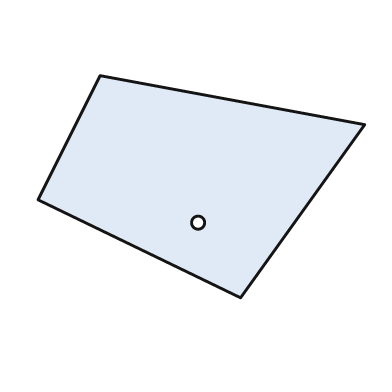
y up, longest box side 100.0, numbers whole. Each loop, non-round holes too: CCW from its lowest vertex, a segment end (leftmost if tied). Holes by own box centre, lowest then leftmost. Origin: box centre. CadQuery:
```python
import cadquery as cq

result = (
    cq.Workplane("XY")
    .moveTo(12.0, -34.0)
    .lineTo(50.0, 19.0)
    .lineTo(-31.0, 34.0)
    .lineTo(-50.0, -4.0)
    .close()
    .moveTo(-1.0, -11.0)
    .circle(2.0)
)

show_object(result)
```